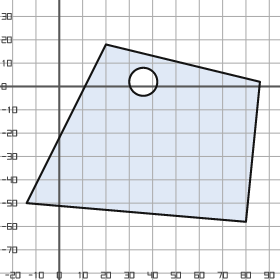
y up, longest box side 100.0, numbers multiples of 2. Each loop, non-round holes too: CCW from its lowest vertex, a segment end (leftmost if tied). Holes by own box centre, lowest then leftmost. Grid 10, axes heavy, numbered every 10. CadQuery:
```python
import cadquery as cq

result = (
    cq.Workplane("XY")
    .moveTo(80.0, -58.0)
    .lineTo(86.0, 2.0)
    .lineTo(20.0, 18.0)
    .lineTo(-14.0, -50.0)
    .close()
    .moveTo(36.0, 2.0)
    .circle(6.0)
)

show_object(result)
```